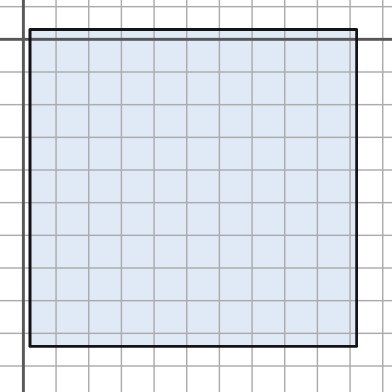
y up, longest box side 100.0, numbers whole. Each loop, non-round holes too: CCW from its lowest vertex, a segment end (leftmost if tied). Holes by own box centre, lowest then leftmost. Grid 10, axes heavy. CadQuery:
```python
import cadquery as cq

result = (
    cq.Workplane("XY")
    .moveTo(2.0, -94.0)
    .lineTo(102.0, -94.0)
    .lineTo(102.0, 3.0)
    .lineTo(2.0, 3.0)
    .close()
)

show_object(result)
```